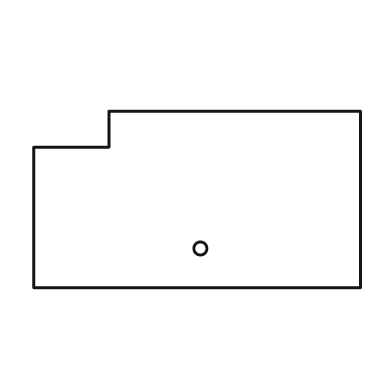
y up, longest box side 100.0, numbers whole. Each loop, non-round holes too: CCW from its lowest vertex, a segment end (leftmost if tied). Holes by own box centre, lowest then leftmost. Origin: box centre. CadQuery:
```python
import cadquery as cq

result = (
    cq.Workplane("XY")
    .moveTo(-50.0, -27.0)
    .lineTo(50.0, -27.0)
    .lineTo(50.0, 27.0)
    .lineTo(-27.0, 27.0)
    .lineTo(-27.0, 16.0)
    .lineTo(-50.0, 16.0)
    .close()
    .moveTo(1.0, -15.0)
    .circle(2.0)
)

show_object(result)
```